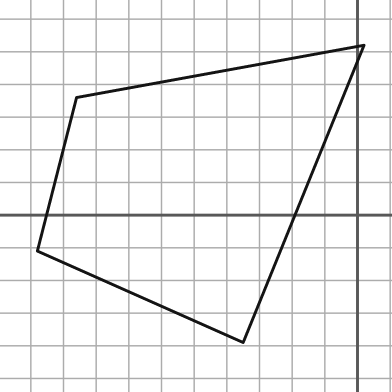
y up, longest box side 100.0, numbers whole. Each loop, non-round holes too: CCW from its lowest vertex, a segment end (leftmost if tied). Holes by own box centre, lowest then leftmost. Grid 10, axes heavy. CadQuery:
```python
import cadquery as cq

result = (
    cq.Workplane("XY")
    .moveTo(-35.0, -39.0)
    .lineTo(2.0, 52.0)
    .lineTo(-86.0, 36.0)
    .lineTo(-98.0, -11.0)
    .close()
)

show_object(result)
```